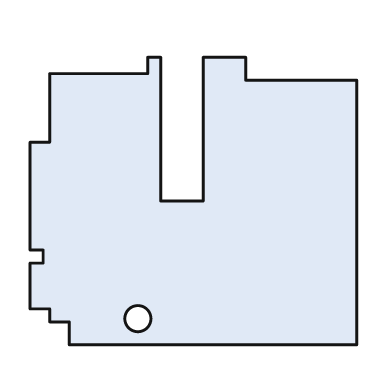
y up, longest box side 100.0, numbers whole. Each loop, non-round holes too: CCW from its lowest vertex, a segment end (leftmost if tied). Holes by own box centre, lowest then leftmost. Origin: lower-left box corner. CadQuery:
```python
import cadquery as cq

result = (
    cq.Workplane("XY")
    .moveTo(12.0, 0.0)
    .lineTo(100.0, 0.0)
    .lineTo(100.0, 81.0)
    .lineTo(66.0, 81.0)
    .lineTo(66.0, 88.0)
    .lineTo(53.0, 88.0)
    .lineTo(53.0, 44.0)
    .lineTo(40.0, 44.0)
    .lineTo(40.0, 88.0)
    .lineTo(36.0, 88.0)
    .lineTo(36.0, 83.0)
    .lineTo(6.0, 83.0)
    .lineTo(6.0, 62.0)
    .lineTo(0.0, 62.0)
    .lineTo(0.0, 29.0)
    .lineTo(4.0, 29.0)
    .lineTo(4.0, 25.0)
    .lineTo(0.0, 25.0)
    .lineTo(0.0, 11.0)
    .lineTo(6.0, 11.0)
    .lineTo(6.0, 7.0)
    .lineTo(12.0, 7.0)
    .close()
    .moveTo(33.0, 8.0)
    .circle(4.0)
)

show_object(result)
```